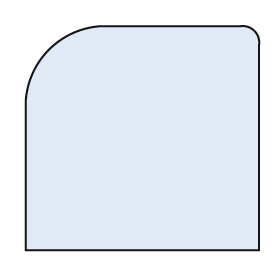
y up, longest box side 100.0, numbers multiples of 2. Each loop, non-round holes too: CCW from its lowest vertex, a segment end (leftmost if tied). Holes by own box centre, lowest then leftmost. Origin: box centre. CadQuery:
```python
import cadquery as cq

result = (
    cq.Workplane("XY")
    .moveTo(-50.0, -48.0)
    .lineTo(50.0, -48.0)
    .lineTo(50.0, 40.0)
    .threePointArc((48.0, 46.0), (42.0, 48.0))
    .lineTo(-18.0, 48.0)
    .threePointArc((-40.0, 38.0), (-50.0, 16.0))
    .close()
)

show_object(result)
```